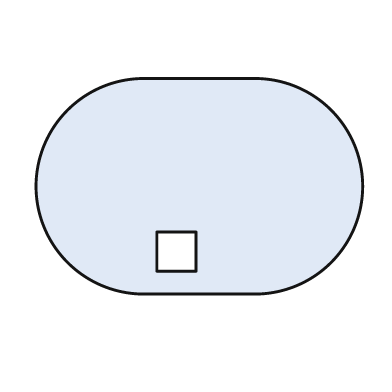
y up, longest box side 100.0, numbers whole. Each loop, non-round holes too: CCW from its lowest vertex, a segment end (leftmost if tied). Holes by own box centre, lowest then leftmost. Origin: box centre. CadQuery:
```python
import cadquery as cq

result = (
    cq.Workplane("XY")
    .moveTo(-17.0, -33.0)
    .lineTo(17.0, -33.0)
    .threePointArc((50.0, 0.0), (17.0, 33.0))
    .lineTo(-17.0, 33.0)
    .threePointArc((-50.0, 0.0), (-17.0, -33.0))
    .close()
    .moveTo(-13.0, -26.0)
    .lineTo(-1.0, -26.0)
    .lineTo(-1.0, -14.0)
    .lineTo(-13.0, -14.0)
    .close()
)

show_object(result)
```